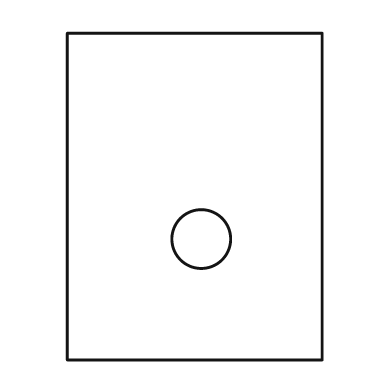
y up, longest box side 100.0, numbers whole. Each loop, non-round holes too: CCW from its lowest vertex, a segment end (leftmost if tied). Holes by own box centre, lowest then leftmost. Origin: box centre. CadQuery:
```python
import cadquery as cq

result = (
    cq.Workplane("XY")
    .moveTo(-39.0, -50.0)
    .lineTo(39.0, -50.0)
    .lineTo(39.0, 50.0)
    .lineTo(-39.0, 50.0)
    .close()
    .moveTo(2.0, -13.0)
    .circle(9.0)
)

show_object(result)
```